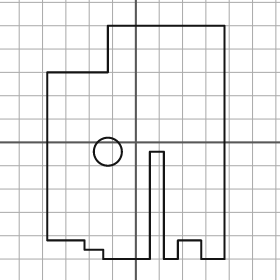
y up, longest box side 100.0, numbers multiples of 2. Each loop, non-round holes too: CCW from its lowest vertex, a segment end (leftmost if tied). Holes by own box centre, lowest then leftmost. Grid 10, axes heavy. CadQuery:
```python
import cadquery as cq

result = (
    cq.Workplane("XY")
    .moveTo(-14.0, -50.0)
    .lineTo(6.0, -50.0)
    .lineTo(6.0, -4.0)
    .lineTo(12.0, -4.0)
    .lineTo(12.0, -50.0)
    .lineTo(18.0, -50.0)
    .lineTo(18.0, -42.0)
    .lineTo(28.0, -42.0)
    .lineTo(28.0, -50.0)
    .lineTo(38.0, -50.0)
    .lineTo(38.0, 50.0)
    .lineTo(-12.0, 50.0)
    .lineTo(-12.0, 30.0)
    .lineTo(-38.0, 30.0)
    .lineTo(-38.0, -42.0)
    .lineTo(-22.0, -42.0)
    .lineTo(-22.0, -46.0)
    .lineTo(-14.0, -46.0)
    .close()
    .moveTo(-12.0, -4.0)
    .circle(6.0)
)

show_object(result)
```